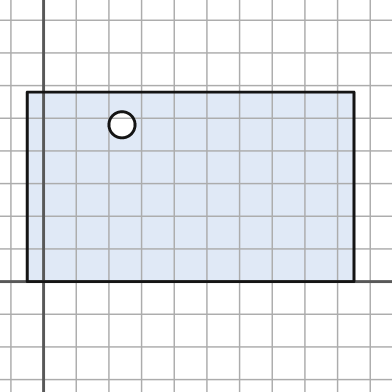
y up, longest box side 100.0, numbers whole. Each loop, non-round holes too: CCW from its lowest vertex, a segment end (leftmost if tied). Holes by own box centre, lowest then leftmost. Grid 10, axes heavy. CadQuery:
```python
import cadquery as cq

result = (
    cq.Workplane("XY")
    .moveTo(-5.0, 0.0)
    .lineTo(95.0, 0.0)
    .lineTo(95.0, 58.0)
    .lineTo(-5.0, 58.0)
    .close()
    .moveTo(24.0, 48.0)
    .circle(4.0)
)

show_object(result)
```